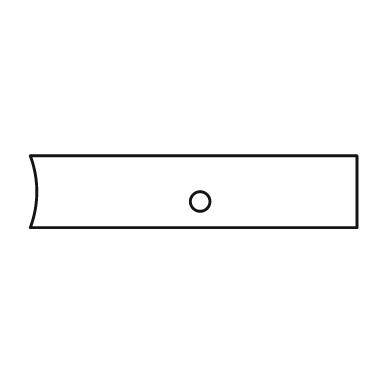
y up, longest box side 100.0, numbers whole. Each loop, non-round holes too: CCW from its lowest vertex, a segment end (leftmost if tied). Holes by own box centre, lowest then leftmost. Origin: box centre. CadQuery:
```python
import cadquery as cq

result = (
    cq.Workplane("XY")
    .moveTo(-50.0, -11.0)
    .lineTo(50.0, -11.0)
    .lineTo(50.0, 11.0)
    .lineTo(-50.0, 11.0)
    .threePointArc((-48.0, 0.0), (-50.0, -11.0))
    .close()
    .moveTo(2.0, -3.0)
    .circle(3.0)
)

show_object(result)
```